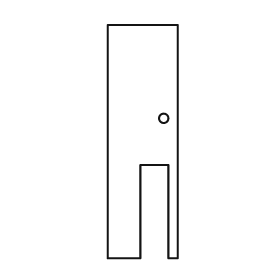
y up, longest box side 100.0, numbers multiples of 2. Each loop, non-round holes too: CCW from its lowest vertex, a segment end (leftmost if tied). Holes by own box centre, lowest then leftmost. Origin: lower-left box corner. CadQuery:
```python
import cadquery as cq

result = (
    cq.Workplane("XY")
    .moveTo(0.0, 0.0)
    .lineTo(14.0, 0.0)
    .lineTo(14.0, 40.0)
    .lineTo(26.0, 40.0)
    .lineTo(26.0, 0.0)
    .lineTo(30.0, 0.0)
    .lineTo(30.0, 100.0)
    .lineTo(0.0, 100.0)
    .close()
    .moveTo(24.0, 60.0)
    .circle(2.0)
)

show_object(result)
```